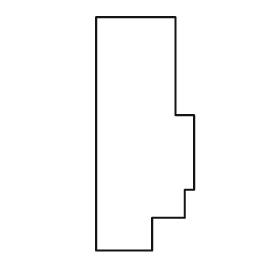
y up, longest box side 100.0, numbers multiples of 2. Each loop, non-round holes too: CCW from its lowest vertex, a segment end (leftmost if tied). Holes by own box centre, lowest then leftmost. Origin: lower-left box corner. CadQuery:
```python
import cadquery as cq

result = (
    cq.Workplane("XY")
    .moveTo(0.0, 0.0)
    .lineTo(24.0, 0.0)
    .lineTo(24.0, 14.0)
    .lineTo(38.0, 14.0)
    .lineTo(38.0, 26.0)
    .lineTo(42.0, 26.0)
    .lineTo(42.0, 58.0)
    .lineTo(34.0, 58.0)
    .lineTo(34.0, 100.0)
    .lineTo(0.0, 100.0)
    .close()
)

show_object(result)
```